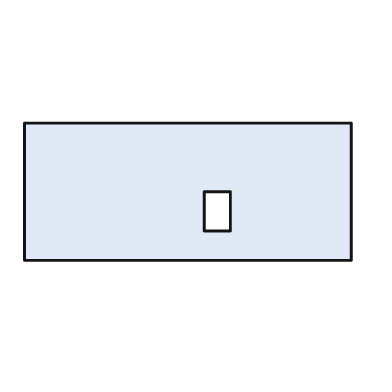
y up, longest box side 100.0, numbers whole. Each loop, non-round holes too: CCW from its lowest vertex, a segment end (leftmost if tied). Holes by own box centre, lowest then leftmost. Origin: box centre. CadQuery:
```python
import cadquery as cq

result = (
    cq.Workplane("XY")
    .moveTo(-50.0, -21.0)
    .lineTo(50.0, -21.0)
    .lineTo(50.0, 21.0)
    .lineTo(-50.0, 21.0)
    .close()
    .moveTo(5.0, -12.0)
    .lineTo(13.0, -12.0)
    .lineTo(13.0, 0.0)
    .lineTo(5.0, 0.0)
    .close()
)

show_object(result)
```